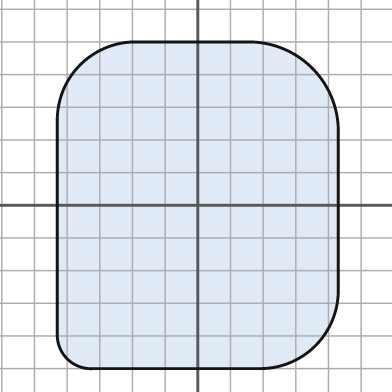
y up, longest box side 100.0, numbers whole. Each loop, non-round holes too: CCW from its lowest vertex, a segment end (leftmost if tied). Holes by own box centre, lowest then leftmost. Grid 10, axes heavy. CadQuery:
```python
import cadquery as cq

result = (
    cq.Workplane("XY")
    .moveTo(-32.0, -50.0)
    .lineTo(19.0, -50.0)
    .threePointArc((36.0, -43.0), (43.0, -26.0))
    .lineTo(43.0, 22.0)
    .threePointArc((35.0, 42.0), (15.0, 50.0))
    .lineTo(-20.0, 50.0)
    .threePointArc((-36.0, 43.0), (-43.0, 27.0))
    .lineTo(-43.0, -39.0)
    .threePointArc((-40.0, -47.0), (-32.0, -50.0))
    .close()
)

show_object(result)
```